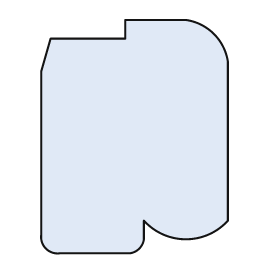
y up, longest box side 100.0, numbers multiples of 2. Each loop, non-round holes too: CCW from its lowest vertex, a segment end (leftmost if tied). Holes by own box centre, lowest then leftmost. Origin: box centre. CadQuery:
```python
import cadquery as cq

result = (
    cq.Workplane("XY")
    .moveTo(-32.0, -50.0)
    .lineTo(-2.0, -50.0)
    .threePointArc((2.0, -48.0), (4.0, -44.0))
    .lineTo(4.0, -36.0)
    .threePointArc((22.0, -44.0), (40.0, -36.0))
    .lineTo(40.0, 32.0)
    .threePointArc((34.0, 44.0), (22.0, 50.0))
    .lineTo(-4.0, 50.0)
    .lineTo(-4.0, 42.0)
    .lineTo(-36.0, 42.0)
    .lineTo(-40.0, 28.0)
    .lineTo(-40.0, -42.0)
    .threePointArc((-38.0, -48.0), (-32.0, -50.0))
    .close()
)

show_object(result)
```